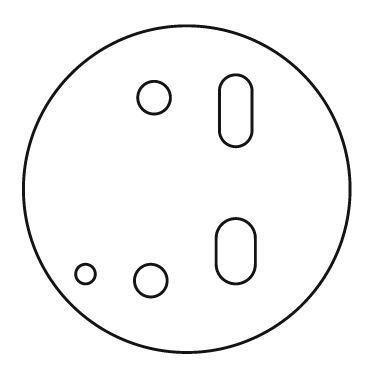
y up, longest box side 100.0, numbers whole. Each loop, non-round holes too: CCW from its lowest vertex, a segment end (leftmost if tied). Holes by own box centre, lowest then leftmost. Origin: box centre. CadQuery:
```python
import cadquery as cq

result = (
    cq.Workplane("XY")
    .moveTo(0.0, 0.0)
    .circle(50.0)
    .moveTo(-11.0, -28.0)
    .circle(5.0)
    .moveTo(-31.0, -26.0)
    .circle(3.0)
    .moveTo(9.0, -23.0)
    .threePointArc((15.0, -29.0), (21.0, -23.0))
    .lineTo(21.0, -15.0)
    .threePointArc((15.0, -9.0), (9.0, -15.0))
    .close()
    .moveTo(10.0, 18.0)
    .threePointArc((15.0, 13.0), (20.0, 18.0))
    .lineTo(20.0, 30.0)
    .threePointArc((15.0, 35.0), (10.0, 30.0))
    .close()
    .moveTo(-10.0, 28.0)
    .circle(5.0)
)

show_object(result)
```